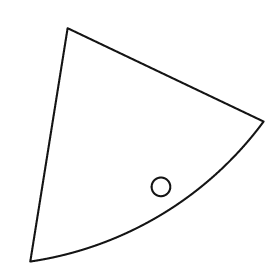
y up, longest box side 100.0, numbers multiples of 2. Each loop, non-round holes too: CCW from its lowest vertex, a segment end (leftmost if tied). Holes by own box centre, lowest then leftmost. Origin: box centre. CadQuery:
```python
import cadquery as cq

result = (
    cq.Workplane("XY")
    .moveTo(-50.0, -50.0)
    .threePointArc((6.0, -30.0), (50.0, 10.0))
    .lineTo(-34.0, 50.0)
    .close()
    .moveTo(6.0, -18.0)
    .circle(4.0)
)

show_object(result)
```